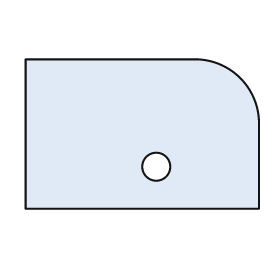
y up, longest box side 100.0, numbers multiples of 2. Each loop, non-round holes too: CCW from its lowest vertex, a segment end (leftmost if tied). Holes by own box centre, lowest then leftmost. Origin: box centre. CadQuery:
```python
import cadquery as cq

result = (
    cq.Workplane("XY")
    .moveTo(-50.0, -32.0)
    .lineTo(50.0, -32.0)
    .lineTo(50.0, 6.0)
    .threePointArc((42.0, 24.0), (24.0, 32.0))
    .lineTo(-50.0, 32.0)
    .close()
    .moveTo(6.0, -14.0)
    .circle(6.0)
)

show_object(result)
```